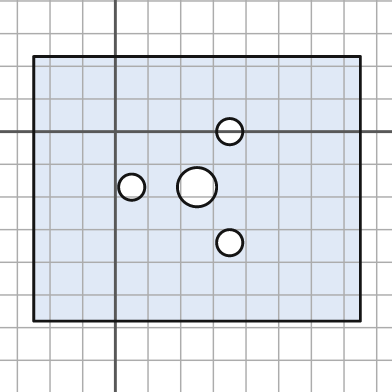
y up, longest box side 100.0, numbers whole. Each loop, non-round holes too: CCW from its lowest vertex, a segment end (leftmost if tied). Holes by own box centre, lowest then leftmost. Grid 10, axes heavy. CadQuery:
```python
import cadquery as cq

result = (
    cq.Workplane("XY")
    .moveTo(-25.0, -58.0)
    .lineTo(75.0, -58.0)
    .lineTo(75.0, 23.0)
    .lineTo(-25.0, 23.0)
    .close()
    .moveTo(35.0, -34.0)
    .circle(4.0)
    .moveTo(5.0, -17.0)
    .circle(4.0)
    .moveTo(25.0, -17.0)
    .circle(6.0)
    .moveTo(35.0, 0.0)
    .circle(4.0)
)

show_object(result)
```